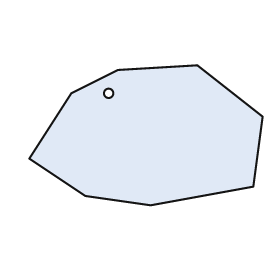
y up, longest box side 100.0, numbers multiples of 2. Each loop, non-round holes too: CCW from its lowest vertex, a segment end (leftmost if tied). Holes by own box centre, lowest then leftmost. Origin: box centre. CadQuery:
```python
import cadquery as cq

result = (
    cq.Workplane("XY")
    .moveTo(2.0, -30.0)
    .lineTo(46.0, -22.0)
    .lineTo(50.0, 8.0)
    .lineTo(22.0, 30.0)
    .lineTo(-12.0, 28.0)
    .lineTo(-32.0, 18.0)
    .lineTo(-50.0, -10.0)
    .lineTo(-26.0, -26.0)
    .close()
    .moveTo(-16.0, 18.0)
    .circle(2.0)
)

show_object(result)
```